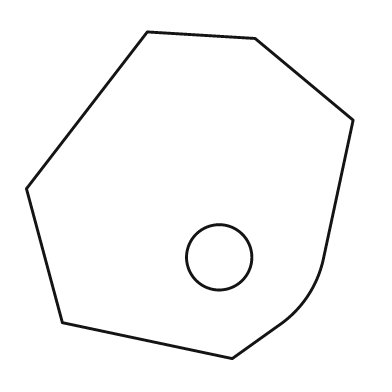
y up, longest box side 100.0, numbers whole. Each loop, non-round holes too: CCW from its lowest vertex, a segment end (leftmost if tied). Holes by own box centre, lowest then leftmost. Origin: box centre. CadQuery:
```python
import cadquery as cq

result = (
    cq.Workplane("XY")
    .moveTo(13.0, -50.0)
    .lineTo(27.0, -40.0)
    .threePointArc((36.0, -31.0), (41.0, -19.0))
    .lineTo(50.0, 23.0)
    .lineTo(20.0, 48.0)
    .lineTo(-13.0, 50.0)
    .lineTo(-50.0, 2.0)
    .lineTo(-39.0, -39.0)
    .close()
    .moveTo(9.0, -19.0)
    .circle(10.0)
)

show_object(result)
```